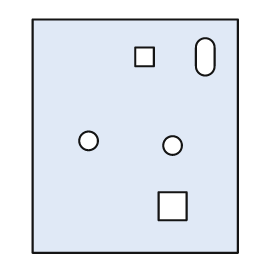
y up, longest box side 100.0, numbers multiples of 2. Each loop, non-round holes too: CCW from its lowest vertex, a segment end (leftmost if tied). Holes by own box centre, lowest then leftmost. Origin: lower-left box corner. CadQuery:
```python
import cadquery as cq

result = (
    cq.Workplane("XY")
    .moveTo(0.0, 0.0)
    .lineTo(88.0, 0.0)
    .lineTo(88.0, 100.0)
    .lineTo(0.0, 100.0)
    .close()
    .moveTo(54.0, 14.0)
    .lineTo(66.0, 14.0)
    .lineTo(66.0, 26.0)
    .lineTo(54.0, 26.0)
    .close()
    .moveTo(60.0, 46.0)
    .circle(4.0)
    .moveTo(24.0, 48.0)
    .circle(4.0)
    .moveTo(44.0, 80.0)
    .lineTo(52.0, 80.0)
    .lineTo(52.0, 88.0)
    .lineTo(44.0, 88.0)
    .close()
    .moveTo(70.0, 80.0)
    .threePointArc((74.0, 76.0), (78.0, 80.0))
    .lineTo(78.0, 88.0)
    .threePointArc((74.0, 92.0), (70.0, 88.0))
    .close()
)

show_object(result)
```